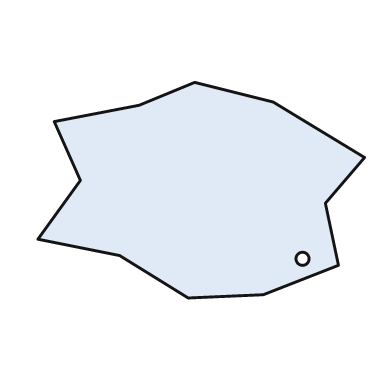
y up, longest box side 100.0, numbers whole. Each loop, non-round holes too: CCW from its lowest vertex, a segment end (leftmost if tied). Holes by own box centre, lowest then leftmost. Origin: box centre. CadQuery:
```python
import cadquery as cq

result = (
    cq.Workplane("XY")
    .moveTo(-4.0, -33.0)
    .lineTo(19.0, -32.0)
    .lineTo(42.0, -23.0)
    .lineTo(38.0, -4.0)
    .lineTo(50.0, 10.0)
    .lineTo(22.0, 27.0)
    .lineTo(-2.0, 33.0)
    .lineTo(-19.0, 26.0)
    .lineTo(-45.0, 21.0)
    .lineTo(-37.0, 3.0)
    .lineTo(-50.0, -15.0)
    .lineTo(-25.0, -20.0)
    .close()
    .moveTo(31.0, -21.0)
    .circle(2.0)
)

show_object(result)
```